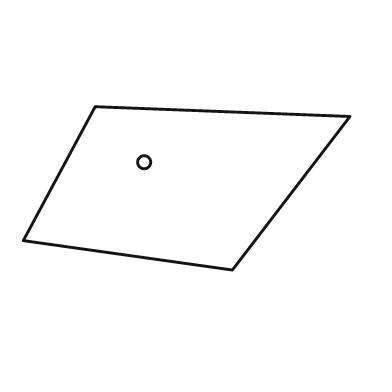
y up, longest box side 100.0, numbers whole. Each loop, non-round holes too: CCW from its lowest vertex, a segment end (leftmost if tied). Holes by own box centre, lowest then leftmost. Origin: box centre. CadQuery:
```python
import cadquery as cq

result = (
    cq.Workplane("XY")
    .moveTo(14.0, -25.0)
    .lineTo(50.0, 22.0)
    .lineTo(-28.0, 25.0)
    .lineTo(-50.0, -16.0)
    .close()
    .moveTo(-13.0, 8.0)
    .circle(2.0)
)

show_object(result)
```